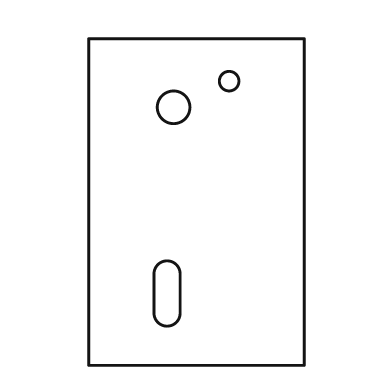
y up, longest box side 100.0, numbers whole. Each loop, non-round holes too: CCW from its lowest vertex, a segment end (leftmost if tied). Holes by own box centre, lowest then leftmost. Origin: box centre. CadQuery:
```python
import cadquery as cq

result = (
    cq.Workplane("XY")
    .moveTo(-33.0, -50.0)
    .lineTo(33.0, -50.0)
    .lineTo(33.0, 50.0)
    .lineTo(-33.0, 50.0)
    .close()
    .moveTo(-13.0, -34.0)
    .threePointArc((-9.0, -38.0), (-5.0, -34.0))
    .lineTo(-5.0, -22.0)
    .threePointArc((-9.0, -18.0), (-13.0, -22.0))
    .close()
    .moveTo(-7.0, 29.0)
    .circle(5.0)
    .moveTo(10.0, 37.0)
    .circle(3.0)
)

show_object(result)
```